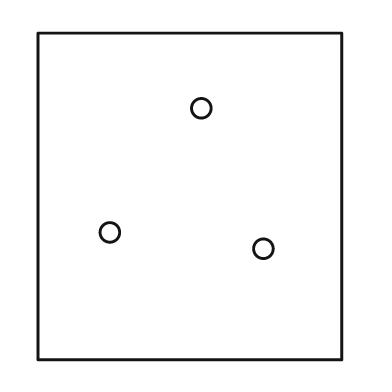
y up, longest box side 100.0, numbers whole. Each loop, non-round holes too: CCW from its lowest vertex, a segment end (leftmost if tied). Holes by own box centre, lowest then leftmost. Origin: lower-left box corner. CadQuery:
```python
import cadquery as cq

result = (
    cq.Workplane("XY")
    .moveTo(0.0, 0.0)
    .lineTo(93.0, 0.0)
    .lineTo(93.0, 100.0)
    .lineTo(0.0, 100.0)
    .close()
    .moveTo(69.0, 34.0)
    .circle(3.0)
    .moveTo(22.0, 39.0)
    .circle(3.0)
    .moveTo(50.0, 77.0)
    .circle(3.0)
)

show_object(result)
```